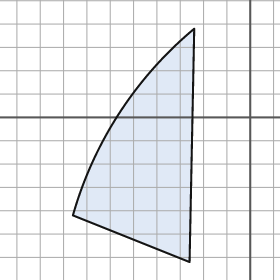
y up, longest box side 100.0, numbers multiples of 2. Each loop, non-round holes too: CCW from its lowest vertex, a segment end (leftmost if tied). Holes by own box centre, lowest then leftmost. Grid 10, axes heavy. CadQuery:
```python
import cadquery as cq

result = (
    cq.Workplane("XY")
    .moveTo(-26.0, -62.0)
    .lineTo(-24.0, 38.0)
    .threePointArc((-56.0, 2.0), (-76.0, -42.0))
    .close()
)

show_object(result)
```